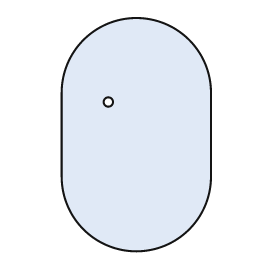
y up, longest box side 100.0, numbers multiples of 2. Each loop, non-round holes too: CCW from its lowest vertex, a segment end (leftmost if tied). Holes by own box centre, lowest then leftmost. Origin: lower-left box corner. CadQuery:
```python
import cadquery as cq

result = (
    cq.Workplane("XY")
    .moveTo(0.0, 32.0)
    .threePointArc((32.0, 0.0), (64.0, 32.0))
    .lineTo(64.0, 68.0)
    .threePointArc((32.0, 100.0), (0.0, 68.0))
    .close()
    .moveTo(20.0, 64.0)
    .circle(2.0)
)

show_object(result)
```